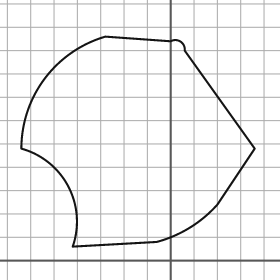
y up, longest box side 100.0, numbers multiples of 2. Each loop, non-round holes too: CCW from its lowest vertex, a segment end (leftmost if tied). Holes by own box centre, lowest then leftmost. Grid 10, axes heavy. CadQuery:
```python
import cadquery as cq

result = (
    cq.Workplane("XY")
    .moveTo(-42.0, 6.0)
    .lineTo(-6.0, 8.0)
    .threePointArc((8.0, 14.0), (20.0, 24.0))
    .lineTo(36.0, 48.0)
    .lineTo(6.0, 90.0)
    .threePointArc((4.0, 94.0), (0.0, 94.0))
    .lineTo(-28.0, 96.0)
    .threePointArc((-54.0, 78.0), (-64.0, 48.0))
    .threePointArc((-44.0, 32.0), (-42.0, 6.0))
    .close()
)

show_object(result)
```